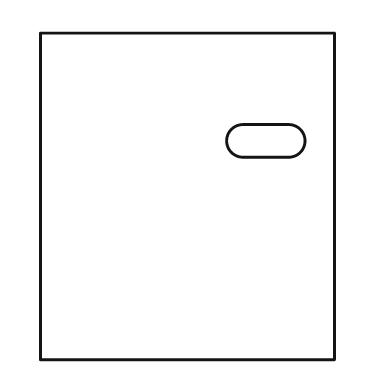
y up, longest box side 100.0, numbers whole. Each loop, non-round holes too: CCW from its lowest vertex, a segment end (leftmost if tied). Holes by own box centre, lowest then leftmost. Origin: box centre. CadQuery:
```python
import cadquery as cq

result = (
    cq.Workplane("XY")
    .moveTo(-45.0, -50.0)
    .lineTo(45.0, -50.0)
    .lineTo(45.0, 50.0)
    .lineTo(-45.0, 50.0)
    .close()
    .moveTo(17.0, 12.0)
    .lineTo(31.0, 12.0)
    .threePointArc((36.0, 17.0), (31.0, 22.0))
    .lineTo(17.0, 22.0)
    .threePointArc((12.0, 17.0), (17.0, 12.0))
    .close()
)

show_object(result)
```